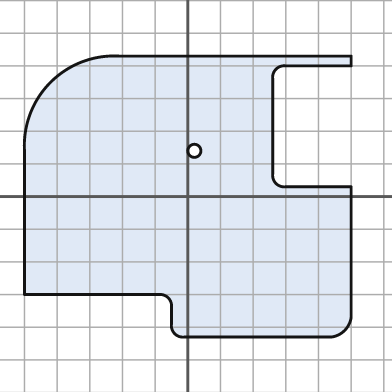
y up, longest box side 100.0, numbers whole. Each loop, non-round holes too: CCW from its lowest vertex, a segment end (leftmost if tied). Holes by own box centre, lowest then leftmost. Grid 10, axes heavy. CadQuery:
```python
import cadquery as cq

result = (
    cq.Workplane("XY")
    .moveTo(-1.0, -43.0)
    .lineTo(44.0, -43.0)
    .threePointArc((48.0, -41.0), (50.0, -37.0))
    .lineTo(50.0, 3.0)
    .lineTo(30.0, 3.0)
    .threePointArc((27.0, 4.0), (26.0, 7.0))
    .lineTo(26.0, 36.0)
    .threePointArc((27.0, 39.0), (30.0, 40.0))
    .lineTo(50.0, 40.0)
    .lineTo(50.0, 43.0)
    .lineTo(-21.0, 43.0)
    .threePointArc((-42.0, 35.0), (-50.0, 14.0))
    .lineTo(-50.0, -30.0)
    .lineTo(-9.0, -30.0)
    .threePointArc((-6.0, -31.0), (-5.0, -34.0))
    .lineTo(-5.0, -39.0)
    .threePointArc((-4.0, -42.0), (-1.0, -43.0))
    .close()
    .moveTo(2.0, 14.0)
    .circle(2.0)
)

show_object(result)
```